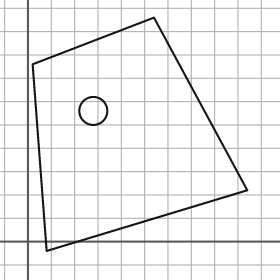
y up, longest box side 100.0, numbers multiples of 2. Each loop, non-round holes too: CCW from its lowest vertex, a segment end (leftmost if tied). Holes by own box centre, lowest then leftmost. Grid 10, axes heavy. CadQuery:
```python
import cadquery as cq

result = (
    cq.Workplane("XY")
    .moveTo(8.0, -4.0)
    .lineTo(94.0, 22.0)
    .lineTo(54.0, 96.0)
    .lineTo(2.0, 76.0)
    .close()
    .moveTo(28.0, 56.0)
    .circle(6.0)
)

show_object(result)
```